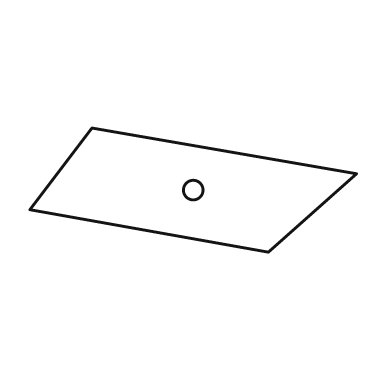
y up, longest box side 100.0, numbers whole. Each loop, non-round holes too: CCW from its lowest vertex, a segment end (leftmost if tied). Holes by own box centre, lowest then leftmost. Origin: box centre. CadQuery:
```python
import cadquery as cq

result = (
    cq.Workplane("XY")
    .moveTo(23.0, -19.0)
    .lineTo(50.0, 5.0)
    .lineTo(-31.0, 19.0)
    .lineTo(-50.0, -6.0)
    .close()
    .moveTo(0.0, 0.0)
    .circle(3.0)
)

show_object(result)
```